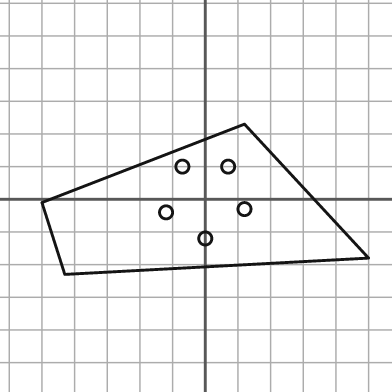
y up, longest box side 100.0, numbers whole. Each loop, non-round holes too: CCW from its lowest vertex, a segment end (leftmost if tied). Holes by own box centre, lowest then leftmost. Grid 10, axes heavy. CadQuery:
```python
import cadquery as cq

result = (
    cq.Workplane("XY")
    .moveTo(-43.0, -23.0)
    .lineTo(50.0, -18.0)
    .lineTo(12.0, 23.0)
    .lineTo(-50.0, -1.0)
    .close()
    .moveTo(0.0, -12.0)
    .circle(2.0)
    .moveTo(-12.0, -4.0)
    .circle(2.0)
    .moveTo(12.0, -3.0)
    .circle(2.0)
    .moveTo(-7.0, 10.0)
    .circle(2.0)
    .moveTo(7.0, 10.0)
    .circle(2.0)
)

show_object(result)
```